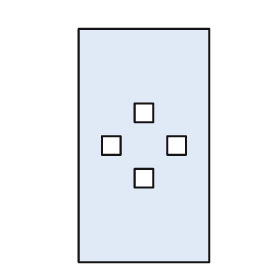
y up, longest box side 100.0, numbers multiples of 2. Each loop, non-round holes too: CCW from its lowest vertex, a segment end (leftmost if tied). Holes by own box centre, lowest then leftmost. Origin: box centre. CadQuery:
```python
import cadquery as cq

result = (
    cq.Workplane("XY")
    .moveTo(-28.0, -50.0)
    .lineTo(28.0, -50.0)
    .lineTo(28.0, 50.0)
    .lineTo(-28.0, 50.0)
    .close()
    .moveTo(-4.0, -18.0)
    .lineTo(4.0, -18.0)
    .lineTo(4.0, -10.0)
    .lineTo(-4.0, -10.0)
    .close()
    .moveTo(-18.0, -4.0)
    .lineTo(-10.0, -4.0)
    .lineTo(-10.0, 4.0)
    .lineTo(-18.0, 4.0)
    .close()
    .moveTo(10.0, -4.0)
    .lineTo(18.0, -4.0)
    .lineTo(18.0, 4.0)
    .lineTo(10.0, 4.0)
    .close()
    .moveTo(-4.0, 10.0)
    .lineTo(4.0, 10.0)
    .lineTo(4.0, 18.0)
    .lineTo(-4.0, 18.0)
    .close()
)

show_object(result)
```